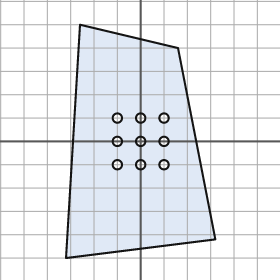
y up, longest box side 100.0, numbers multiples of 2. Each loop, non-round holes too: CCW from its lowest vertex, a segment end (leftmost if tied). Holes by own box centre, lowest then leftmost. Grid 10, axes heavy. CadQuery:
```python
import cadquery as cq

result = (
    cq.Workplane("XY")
    .moveTo(-32.0, -50.0)
    .lineTo(32.0, -42.0)
    .lineTo(16.0, 40.0)
    .lineTo(-26.0, 50.0)
    .close()
    .moveTo(-10.0, -10.0)
    .circle(2.0)
    .moveTo(0.0, -10.0)
    .circle(2.0)
    .moveTo(10.0, -10.0)
    .circle(2.0)
    .moveTo(-10.0, 0.0)
    .circle(2.0)
    .moveTo(0.0, 0.0)
    .circle(2.0)
    .moveTo(10.0, 0.0)
    .circle(2.0)
    .moveTo(-10.0, 10.0)
    .circle(2.0)
    .moveTo(0.0, 10.0)
    .circle(2.0)
    .moveTo(10.0, 10.0)
    .circle(2.0)
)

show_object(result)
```